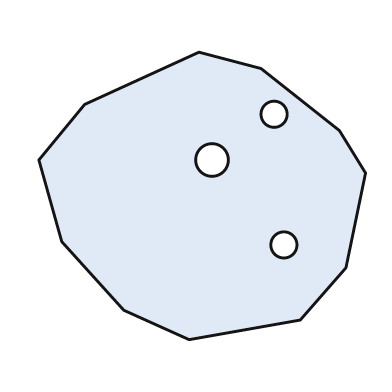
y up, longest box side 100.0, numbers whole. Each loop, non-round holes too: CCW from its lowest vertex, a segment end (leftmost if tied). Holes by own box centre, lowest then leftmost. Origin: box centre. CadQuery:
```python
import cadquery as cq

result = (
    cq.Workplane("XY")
    .moveTo(-4.0, -44.0)
    .lineTo(30.0, -38.0)
    .lineTo(44.0, -22.0)
    .lineTo(50.0, 7.0)
    .lineTo(42.0, 20.0)
    .lineTo(18.0, 39.0)
    .lineTo(-1.0, 44.0)
    .lineTo(-36.0, 28.0)
    .lineTo(-50.0, 11.0)
    .lineTo(-43.0, -14.0)
    .lineTo(-24.0, -35.0)
    .close()
    .moveTo(25.0, -15.0)
    .circle(4.0)
    .moveTo(3.0, 11.0)
    .circle(5.0)
    .moveTo(22.0, 25.0)
    .circle(4.0)
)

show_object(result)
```